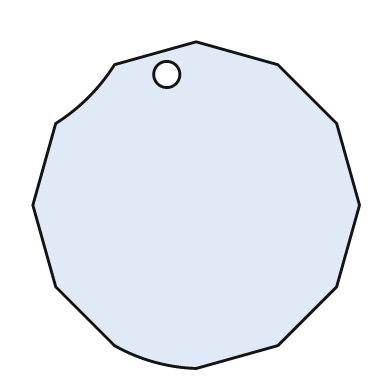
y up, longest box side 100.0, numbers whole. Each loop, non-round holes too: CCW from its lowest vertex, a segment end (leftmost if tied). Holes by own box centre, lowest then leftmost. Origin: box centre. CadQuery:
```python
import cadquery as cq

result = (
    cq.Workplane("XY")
    .moveTo(0.0, -50.0)
    .lineTo(25.0, -43.0)
    .lineTo(43.0, -25.0)
    .lineTo(50.0, 0.0)
    .lineTo(43.0, 25.0)
    .lineTo(25.0, 43.0)
    .lineTo(0.0, 50.0)
    .lineTo(-25.0, 43.0)
    .threePointArc((-33.0, 33.0), (-43.0, 25.0))
    .lineTo(-50.0, 0.0)
    .lineTo(-43.0, -25.0)
    .lineTo(-25.0, -43.0)
    .threePointArc((-13.0, -48.0), (0.0, -50.0))
    .close()
    .moveTo(-9.0, 40.0)
    .circle(4.0)
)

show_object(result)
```